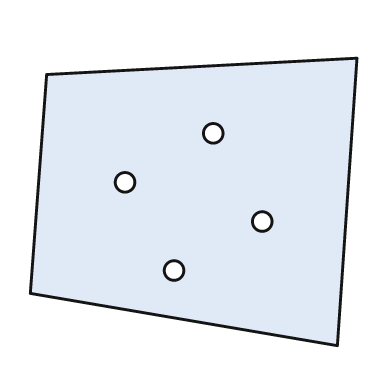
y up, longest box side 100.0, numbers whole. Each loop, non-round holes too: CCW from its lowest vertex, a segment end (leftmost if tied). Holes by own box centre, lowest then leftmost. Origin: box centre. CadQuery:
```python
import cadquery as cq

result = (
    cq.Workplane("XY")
    .moveTo(44.0, -44.0)
    .lineTo(50.0, 44.0)
    .lineTo(-45.0, 39.0)
    .lineTo(-50.0, -28.0)
    .close()
    .moveTo(-6.0, -21.0)
    .circle(3.0)
    .moveTo(21.0, -6.0)
    .circle(3.0)
    .moveTo(-21.0, 6.0)
    .circle(3.0)
    .moveTo(6.0, 21.0)
    .circle(3.0)
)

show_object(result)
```